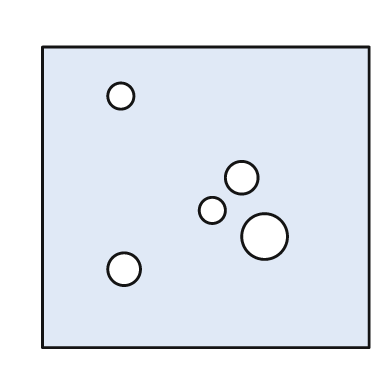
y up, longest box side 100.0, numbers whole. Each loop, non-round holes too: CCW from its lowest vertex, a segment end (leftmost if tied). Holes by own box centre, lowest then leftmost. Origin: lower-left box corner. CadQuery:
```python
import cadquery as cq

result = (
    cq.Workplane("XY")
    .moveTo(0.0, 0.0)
    .lineTo(100.0, 0.0)
    .lineTo(100.0, 92.0)
    .lineTo(0.0, 92.0)
    .close()
    .moveTo(25.0, 24.0)
    .circle(5.0)
    .moveTo(68.0, 34.0)
    .circle(7.0)
    .moveTo(52.0, 42.0)
    .circle(4.0)
    .moveTo(61.0, 52.0)
    .circle(5.0)
    .moveTo(24.0, 77.0)
    .circle(4.0)
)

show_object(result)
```